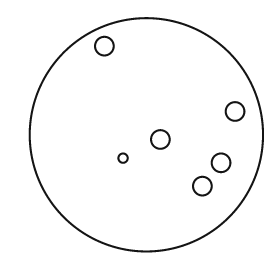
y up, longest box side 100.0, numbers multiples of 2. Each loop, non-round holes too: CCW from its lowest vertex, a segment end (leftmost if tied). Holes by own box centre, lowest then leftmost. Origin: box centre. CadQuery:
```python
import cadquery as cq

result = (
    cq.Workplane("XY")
    .moveTo(0.0, 0.0)
    .circle(50.0)
    .moveTo(24.0, -22.0)
    .circle(4.0)
    .moveTo(32.0, -12.0)
    .circle(4.0)
    .moveTo(-10.0, -10.0)
    .circle(2.0)
    .moveTo(6.0, -2.0)
    .circle(4.0)
    .moveTo(38.0, 10.0)
    .circle(4.0)
    .moveTo(-18.0, 38.0)
    .circle(4.0)
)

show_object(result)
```